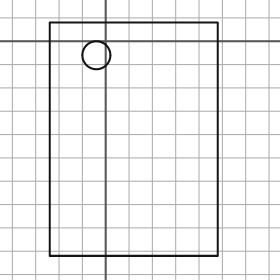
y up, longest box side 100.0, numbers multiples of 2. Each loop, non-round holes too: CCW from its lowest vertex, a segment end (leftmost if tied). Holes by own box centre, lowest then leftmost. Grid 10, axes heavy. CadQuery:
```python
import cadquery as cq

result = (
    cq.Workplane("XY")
    .moveTo(-24.0, -92.0)
    .lineTo(48.0, -92.0)
    .lineTo(48.0, 8.0)
    .lineTo(-24.0, 8.0)
    .close()
    .moveTo(-4.0, -6.0)
    .circle(6.0)
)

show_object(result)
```